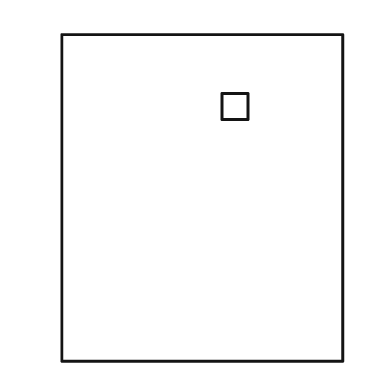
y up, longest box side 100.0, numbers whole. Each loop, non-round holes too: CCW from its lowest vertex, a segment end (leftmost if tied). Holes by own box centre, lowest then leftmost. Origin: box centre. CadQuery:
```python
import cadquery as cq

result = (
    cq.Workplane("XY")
    .moveTo(-43.0, -50.0)
    .lineTo(43.0, -50.0)
    .lineTo(43.0, 50.0)
    .lineTo(-43.0, 50.0)
    .close()
    .moveTo(6.0, 24.0)
    .lineTo(14.0, 24.0)
    .lineTo(14.0, 32.0)
    .lineTo(6.0, 32.0)
    .close()
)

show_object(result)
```